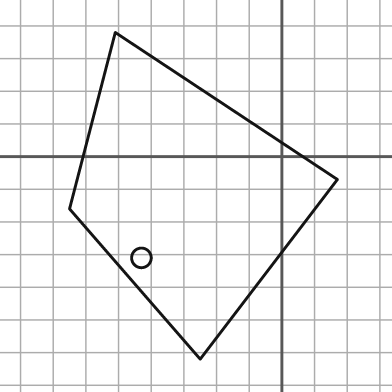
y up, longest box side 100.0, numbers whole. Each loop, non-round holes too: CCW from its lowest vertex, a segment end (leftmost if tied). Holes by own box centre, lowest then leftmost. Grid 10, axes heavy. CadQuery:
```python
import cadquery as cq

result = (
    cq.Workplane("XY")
    .moveTo(-25.0, -62.0)
    .lineTo(17.0, -7.0)
    .lineTo(-51.0, 38.0)
    .lineTo(-65.0, -16.0)
    .close()
    .moveTo(-43.0, -31.0)
    .circle(3.0)
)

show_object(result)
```